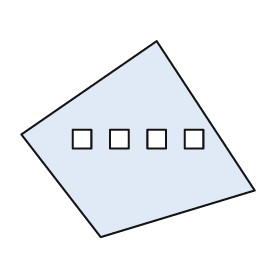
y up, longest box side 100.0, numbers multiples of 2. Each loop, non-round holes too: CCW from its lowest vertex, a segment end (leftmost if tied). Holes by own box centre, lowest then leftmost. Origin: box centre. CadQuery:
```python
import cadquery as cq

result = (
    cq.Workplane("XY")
    .moveTo(-16.0, -42.0)
    .lineTo(50.0, -22.0)
    .lineTo(8.0, 42.0)
    .lineTo(-50.0, 2.0)
    .close()
    .moveTo(-28.0, -4.0)
    .lineTo(-20.0, -4.0)
    .lineTo(-20.0, 4.0)
    .lineTo(-28.0, 4.0)
    .close()
    .moveTo(-12.0, -4.0)
    .lineTo(-4.0, -4.0)
    .lineTo(-4.0, 4.0)
    .lineTo(-12.0, 4.0)
    .close()
    .moveTo(4.0, -4.0)
    .lineTo(12.0, -4.0)
    .lineTo(12.0, 4.0)
    .lineTo(4.0, 4.0)
    .close()
    .moveTo(20.0, -4.0)
    .lineTo(28.0, -4.0)
    .lineTo(28.0, 4.0)
    .lineTo(20.0, 4.0)
    .close()
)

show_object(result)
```